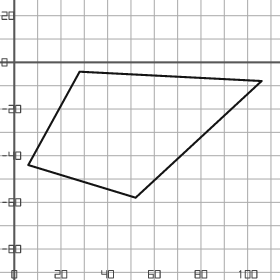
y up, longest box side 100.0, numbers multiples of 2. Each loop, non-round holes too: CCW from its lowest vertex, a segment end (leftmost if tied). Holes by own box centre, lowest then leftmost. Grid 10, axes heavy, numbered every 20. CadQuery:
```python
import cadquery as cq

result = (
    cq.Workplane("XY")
    .moveTo(52.0, -58.0)
    .lineTo(106.0, -8.0)
    .lineTo(28.0, -4.0)
    .lineTo(6.0, -44.0)
    .close()
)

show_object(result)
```